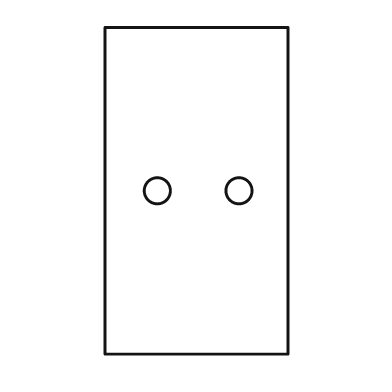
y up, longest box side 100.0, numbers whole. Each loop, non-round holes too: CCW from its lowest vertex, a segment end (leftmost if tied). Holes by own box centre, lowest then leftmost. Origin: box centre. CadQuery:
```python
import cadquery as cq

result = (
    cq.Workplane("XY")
    .moveTo(-28.0, -50.0)
    .lineTo(28.0, -50.0)
    .lineTo(28.0, 50.0)
    .lineTo(-28.0, 50.0)
    .close()
    .moveTo(-12.0, 0.0)
    .circle(4.0)
    .moveTo(13.0, 0.0)
    .circle(4.0)
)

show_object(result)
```